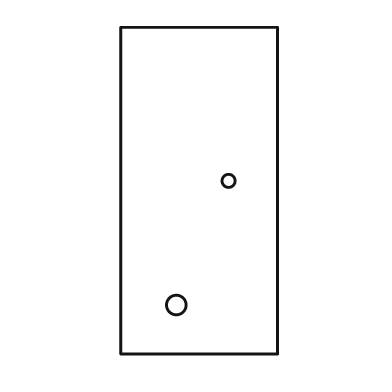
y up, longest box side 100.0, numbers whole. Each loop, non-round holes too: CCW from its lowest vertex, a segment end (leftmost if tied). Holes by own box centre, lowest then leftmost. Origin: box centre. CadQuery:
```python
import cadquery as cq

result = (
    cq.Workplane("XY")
    .moveTo(-24.0, -50.0)
    .lineTo(24.0, -50.0)
    .lineTo(24.0, 50.0)
    .lineTo(-24.0, 50.0)
    .close()
    .moveTo(-7.0, -35.0)
    .circle(3.0)
    .moveTo(9.0, 3.0)
    .circle(2.0)
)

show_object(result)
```